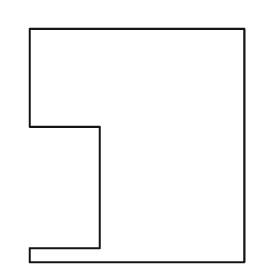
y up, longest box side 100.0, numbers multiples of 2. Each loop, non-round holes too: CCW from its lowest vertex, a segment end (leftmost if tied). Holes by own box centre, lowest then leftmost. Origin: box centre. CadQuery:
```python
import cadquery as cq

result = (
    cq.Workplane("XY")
    .moveTo(-46.0, -50.0)
    .lineTo(46.0, -50.0)
    .lineTo(46.0, 50.0)
    .lineTo(-46.0, 50.0)
    .lineTo(-46.0, 8.0)
    .lineTo(-16.0, 8.0)
    .lineTo(-16.0, -44.0)
    .lineTo(-46.0, -44.0)
    .close()
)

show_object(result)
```